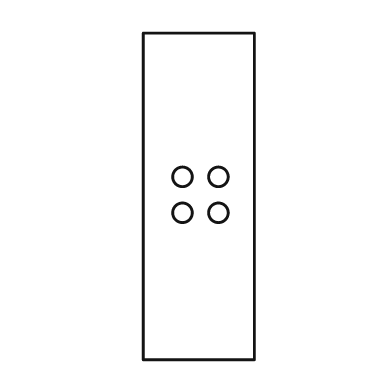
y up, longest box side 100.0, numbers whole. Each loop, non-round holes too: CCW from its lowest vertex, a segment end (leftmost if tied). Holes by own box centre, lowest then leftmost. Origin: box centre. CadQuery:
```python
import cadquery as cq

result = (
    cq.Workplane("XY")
    .moveTo(-17.0, -50.0)
    .lineTo(17.0, -50.0)
    .lineTo(17.0, 50.0)
    .lineTo(-17.0, 50.0)
    .close()
    .moveTo(-5.0, -5.0)
    .circle(3.0)
    .moveTo(6.0, -5.0)
    .circle(3.0)
    .moveTo(-5.0, 6.0)
    .circle(3.0)
    .moveTo(6.0, 6.0)
    .circle(3.0)
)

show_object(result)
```